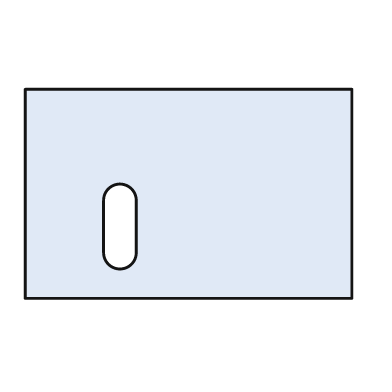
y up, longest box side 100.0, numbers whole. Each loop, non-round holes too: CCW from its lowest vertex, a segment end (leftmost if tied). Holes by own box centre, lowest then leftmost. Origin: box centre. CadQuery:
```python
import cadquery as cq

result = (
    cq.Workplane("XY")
    .moveTo(-50.0, -32.0)
    .lineTo(50.0, -32.0)
    .lineTo(50.0, 32.0)
    .lineTo(-50.0, 32.0)
    .close()
    .moveTo(-26.0, -18.0)
    .threePointArc((-21.0, -23.0), (-16.0, -18.0))
    .lineTo(-16.0, -2.0)
    .threePointArc((-21.0, 3.0), (-26.0, -2.0))
    .close()
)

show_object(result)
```